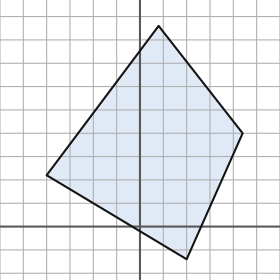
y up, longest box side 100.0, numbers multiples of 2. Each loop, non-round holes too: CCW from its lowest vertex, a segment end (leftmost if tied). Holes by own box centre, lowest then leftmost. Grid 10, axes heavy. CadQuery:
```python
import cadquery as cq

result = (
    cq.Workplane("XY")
    .moveTo(20.0, -14.0)
    .lineTo(44.0, 40.0)
    .lineTo(8.0, 86.0)
    .lineTo(-40.0, 22.0)
    .close()
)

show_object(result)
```